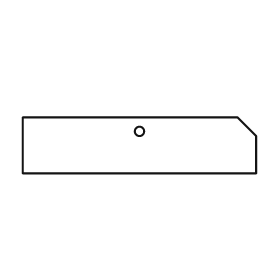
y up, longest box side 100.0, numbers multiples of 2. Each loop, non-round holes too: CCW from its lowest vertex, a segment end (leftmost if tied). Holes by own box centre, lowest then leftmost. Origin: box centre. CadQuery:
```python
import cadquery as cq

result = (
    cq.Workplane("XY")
    .moveTo(-50.0, -12.0)
    .lineTo(50.0, -12.0)
    .lineTo(50.0, 4.0)
    .lineTo(42.0, 12.0)
    .lineTo(-50.0, 12.0)
    .close()
    .moveTo(0.0, 6.0)
    .circle(2.0)
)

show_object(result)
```